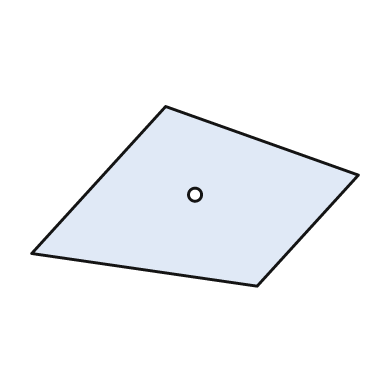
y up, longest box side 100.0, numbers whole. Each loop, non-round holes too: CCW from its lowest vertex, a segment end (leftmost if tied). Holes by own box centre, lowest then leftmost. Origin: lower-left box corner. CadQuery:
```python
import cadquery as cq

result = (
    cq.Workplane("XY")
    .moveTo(69.0, 0.0)
    .lineTo(100.0, 34.0)
    .lineTo(41.0, 55.0)
    .lineTo(0.0, 10.0)
    .close()
    .moveTo(50.0, 28.0)
    .circle(2.0)
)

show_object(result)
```